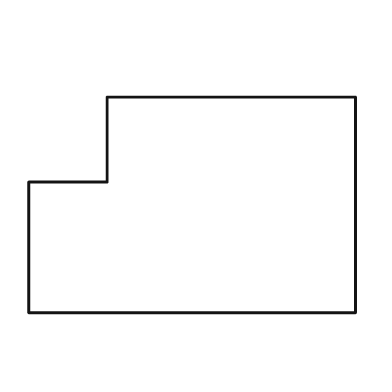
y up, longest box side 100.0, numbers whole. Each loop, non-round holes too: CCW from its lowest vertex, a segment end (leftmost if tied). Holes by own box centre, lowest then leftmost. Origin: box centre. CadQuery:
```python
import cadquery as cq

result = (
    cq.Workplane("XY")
    .moveTo(-50.0, -33.0)
    .lineTo(50.0, -33.0)
    .lineTo(50.0, 33.0)
    .lineTo(-26.0, 33.0)
    .lineTo(-26.0, 7.0)
    .lineTo(-50.0, 7.0)
    .close()
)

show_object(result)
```